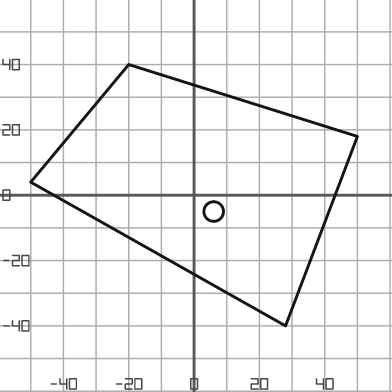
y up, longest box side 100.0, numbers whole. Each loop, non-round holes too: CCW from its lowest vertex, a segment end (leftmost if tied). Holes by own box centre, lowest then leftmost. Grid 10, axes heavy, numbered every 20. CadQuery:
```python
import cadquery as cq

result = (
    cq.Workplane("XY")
    .moveTo(28.0, -40.0)
    .lineTo(50.0, 18.0)
    .lineTo(-20.0, 40.0)
    .lineTo(-50.0, 4.0)
    .close()
    .moveTo(6.0, -5.0)
    .circle(3.0)
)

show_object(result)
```